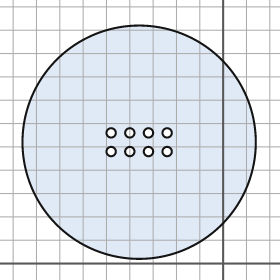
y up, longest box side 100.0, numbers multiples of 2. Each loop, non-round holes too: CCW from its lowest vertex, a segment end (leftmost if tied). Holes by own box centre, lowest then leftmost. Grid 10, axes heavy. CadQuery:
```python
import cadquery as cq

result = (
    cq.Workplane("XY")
    .moveTo(-36.0, 52.0)
    .circle(50.0)
    .moveTo(-48.0, 48.0)
    .circle(2.0)
    .moveTo(-40.0, 48.0)
    .circle(2.0)
    .moveTo(-32.0, 48.0)
    .circle(2.0)
    .moveTo(-24.0, 48.0)
    .circle(2.0)
    .moveTo(-48.0, 56.0)
    .circle(2.0)
    .moveTo(-40.0, 56.0)
    .circle(2.0)
    .moveTo(-32.0, 56.0)
    .circle(2.0)
    .moveTo(-24.0, 56.0)
    .circle(2.0)
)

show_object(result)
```